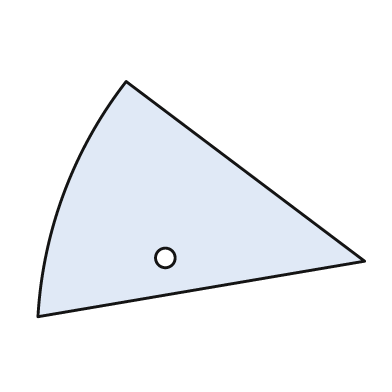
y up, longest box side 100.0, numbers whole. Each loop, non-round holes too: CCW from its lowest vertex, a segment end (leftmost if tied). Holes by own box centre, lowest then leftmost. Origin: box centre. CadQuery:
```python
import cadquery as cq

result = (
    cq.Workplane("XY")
    .moveTo(-50.0, -36.0)
    .lineTo(50.0, -19.0)
    .lineTo(-23.0, 36.0)
    .threePointArc((-42.0, 2.0), (-50.0, -36.0))
    .close()
    .moveTo(-11.0, -18.0)
    .circle(3.0)
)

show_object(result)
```